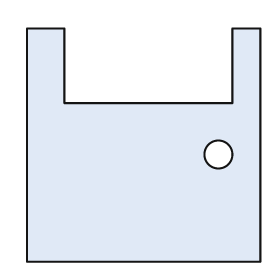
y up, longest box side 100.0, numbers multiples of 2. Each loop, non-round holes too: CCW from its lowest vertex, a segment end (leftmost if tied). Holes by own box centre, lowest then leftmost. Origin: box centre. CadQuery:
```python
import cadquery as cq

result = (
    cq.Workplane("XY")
    .moveTo(-50.0, -50.0)
    .lineTo(50.0, -50.0)
    .lineTo(50.0, 50.0)
    .lineTo(38.0, 50.0)
    .lineTo(38.0, 18.0)
    .lineTo(-34.0, 18.0)
    .lineTo(-34.0, 50.0)
    .lineTo(-50.0, 50.0)
    .close()
    .moveTo(32.0, -4.0)
    .circle(6.0)
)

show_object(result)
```